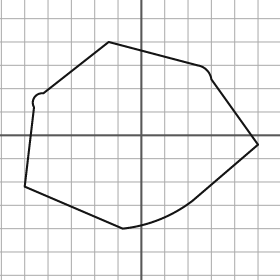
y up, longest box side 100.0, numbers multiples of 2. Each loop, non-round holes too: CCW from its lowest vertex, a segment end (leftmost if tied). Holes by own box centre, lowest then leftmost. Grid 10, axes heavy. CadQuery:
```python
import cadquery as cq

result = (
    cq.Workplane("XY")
    .moveTo(-8.0, -40.0)
    .threePointArc((8.0, -36.0), (22.0, -28.0))
    .lineTo(50.0, -4.0)
    .lineTo(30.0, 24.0)
    .threePointArc((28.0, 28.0), (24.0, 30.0))
    .lineTo(-14.0, 40.0)
    .lineTo(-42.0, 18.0)
    .threePointArc((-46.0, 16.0), (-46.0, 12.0))
    .lineTo(-50.0, -22.0)
    .close()
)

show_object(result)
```